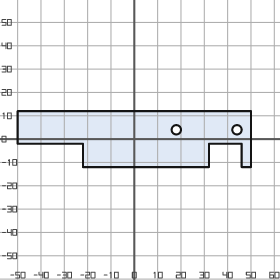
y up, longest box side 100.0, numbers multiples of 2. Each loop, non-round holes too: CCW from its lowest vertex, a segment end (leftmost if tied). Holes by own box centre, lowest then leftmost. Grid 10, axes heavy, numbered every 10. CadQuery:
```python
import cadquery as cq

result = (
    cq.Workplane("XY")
    .moveTo(-22.0, -12.0)
    .lineTo(32.0, -12.0)
    .lineTo(32.0, -2.0)
    .lineTo(46.0, -2.0)
    .lineTo(46.0, -12.0)
    .lineTo(50.0, -12.0)
    .lineTo(50.0, 12.0)
    .lineTo(-50.0, 12.0)
    .lineTo(-50.0, -2.0)
    .lineTo(-22.0, -2.0)
    .close()
    .moveTo(18.0, 4.0)
    .circle(2.0)
    .moveTo(44.0, 4.0)
    .circle(2.0)
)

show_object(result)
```